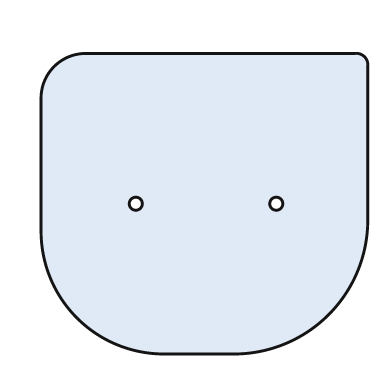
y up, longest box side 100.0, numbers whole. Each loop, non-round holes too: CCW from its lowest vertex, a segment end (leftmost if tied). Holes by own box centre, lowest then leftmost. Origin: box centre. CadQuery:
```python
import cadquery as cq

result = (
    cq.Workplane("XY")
    .moveTo(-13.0, -46.0)
    .lineTo(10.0, -46.0)
    .threePointArc((38.0, -34.0), (50.0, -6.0))
    .lineTo(50.0, 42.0)
    .threePointArc((49.0, 45.0), (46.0, 46.0))
    .lineTo(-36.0, 46.0)
    .threePointArc((-46.0, 42.0), (-50.0, 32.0))
    .lineTo(-50.0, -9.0)
    .threePointArc((-39.0, -35.0), (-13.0, -46.0))
    .close()
    .moveTo(-21.0, 0.0)
    .circle(2.0)
    .moveTo(22.0, 0.0)
    .circle(2.0)
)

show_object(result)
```